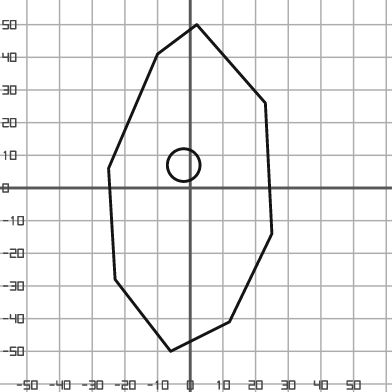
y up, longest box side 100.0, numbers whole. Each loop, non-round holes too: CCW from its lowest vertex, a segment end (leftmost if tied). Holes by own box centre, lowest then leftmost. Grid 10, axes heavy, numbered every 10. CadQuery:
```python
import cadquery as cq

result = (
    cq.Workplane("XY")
    .moveTo(-6.0, -50.0)
    .lineTo(12.0, -41.0)
    .lineTo(25.0, -14.0)
    .lineTo(23.0, 26.0)
    .lineTo(2.0, 50.0)
    .lineTo(-10.0, 41.0)
    .lineTo(-25.0, 6.0)
    .lineTo(-23.0, -28.0)
    .close()
    .moveTo(-2.0, 7.0)
    .circle(5.0)
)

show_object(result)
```